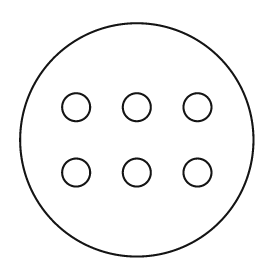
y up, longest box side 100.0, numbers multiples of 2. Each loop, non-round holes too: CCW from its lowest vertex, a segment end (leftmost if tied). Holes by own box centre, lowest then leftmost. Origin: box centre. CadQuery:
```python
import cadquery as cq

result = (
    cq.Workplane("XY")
    .moveTo(0.0, 0.0)
    .circle(50.0)
    .moveTo(-26.0, -14.0)
    .circle(6.0)
    .moveTo(0.0, -14.0)
    .circle(6.0)
    .moveTo(26.0, -14.0)
    .circle(6.0)
    .moveTo(-26.0, 14.0)
    .circle(6.0)
    .moveTo(0.0, 14.0)
    .circle(6.0)
    .moveTo(26.0, 14.0)
    .circle(6.0)
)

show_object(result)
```